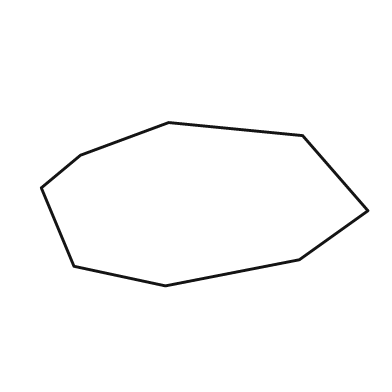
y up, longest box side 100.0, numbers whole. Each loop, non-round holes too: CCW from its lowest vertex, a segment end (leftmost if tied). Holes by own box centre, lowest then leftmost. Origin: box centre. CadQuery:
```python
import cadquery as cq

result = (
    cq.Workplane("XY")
    .moveTo(-12.0, -25.0)
    .lineTo(29.0, -17.0)
    .lineTo(50.0, -2.0)
    .lineTo(30.0, 21.0)
    .lineTo(-11.0, 25.0)
    .lineTo(-38.0, 15.0)
    .lineTo(-50.0, 5.0)
    .lineTo(-40.0, -19.0)
    .close()
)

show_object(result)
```